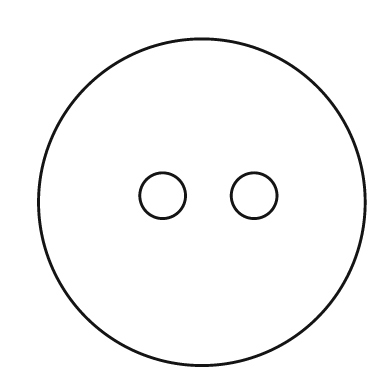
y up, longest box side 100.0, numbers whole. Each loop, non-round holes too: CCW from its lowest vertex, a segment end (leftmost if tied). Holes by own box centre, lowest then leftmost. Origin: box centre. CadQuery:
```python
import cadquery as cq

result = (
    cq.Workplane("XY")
    .moveTo(0.0, 0.0)
    .circle(50.0)
    .moveTo(-12.0, 2.0)
    .circle(7.0)
    .moveTo(16.0, 2.0)
    .circle(7.0)
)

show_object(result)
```